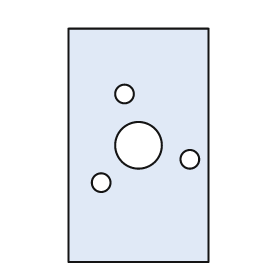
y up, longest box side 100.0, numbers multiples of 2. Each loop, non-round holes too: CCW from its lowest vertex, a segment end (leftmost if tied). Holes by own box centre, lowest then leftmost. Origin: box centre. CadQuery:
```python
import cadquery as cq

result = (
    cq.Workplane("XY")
    .moveTo(-30.0, -50.0)
    .lineTo(30.0, -50.0)
    .lineTo(30.0, 50.0)
    .lineTo(-30.0, 50.0)
    .close()
    .moveTo(-16.0, -16.0)
    .circle(4.0)
    .moveTo(22.0, -6.0)
    .circle(4.0)
    .moveTo(0.0, 0.0)
    .circle(10.0)
    .moveTo(-6.0, 22.0)
    .circle(4.0)
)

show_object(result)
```